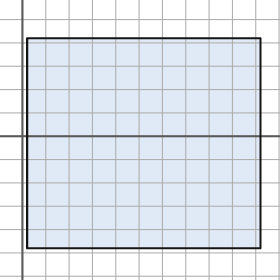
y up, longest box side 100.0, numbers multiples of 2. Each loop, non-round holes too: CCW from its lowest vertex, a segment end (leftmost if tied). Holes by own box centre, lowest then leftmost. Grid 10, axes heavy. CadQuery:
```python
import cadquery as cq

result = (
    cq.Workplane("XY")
    .moveTo(2.0, -48.0)
    .lineTo(102.0, -48.0)
    .lineTo(102.0, 42.0)
    .lineTo(2.0, 42.0)
    .close()
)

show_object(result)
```